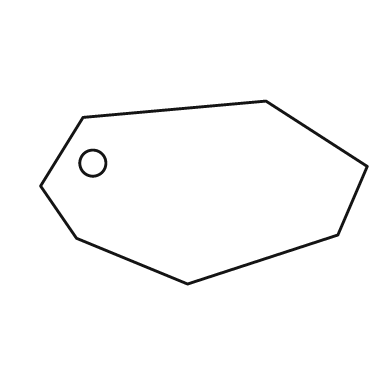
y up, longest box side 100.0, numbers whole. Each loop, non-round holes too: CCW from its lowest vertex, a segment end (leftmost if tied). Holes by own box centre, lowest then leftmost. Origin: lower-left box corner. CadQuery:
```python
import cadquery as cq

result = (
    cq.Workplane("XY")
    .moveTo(45.0, 0.0)
    .lineTo(91.0, 15.0)
    .lineTo(100.0, 36.0)
    .lineTo(69.0, 56.0)
    .lineTo(13.0, 51.0)
    .lineTo(0.0, 30.0)
    .lineTo(11.0, 14.0)
    .close()
    .moveTo(16.0, 37.0)
    .circle(4.0)
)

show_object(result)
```